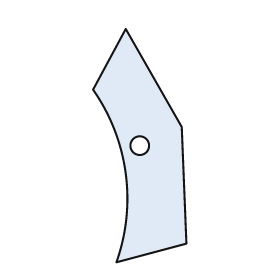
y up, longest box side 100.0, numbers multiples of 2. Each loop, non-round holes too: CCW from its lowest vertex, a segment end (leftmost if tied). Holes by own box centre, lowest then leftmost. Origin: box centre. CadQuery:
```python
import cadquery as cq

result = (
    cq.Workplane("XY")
    .moveTo(-10.0, -50.0)
    .lineTo(20.0, -42.0)
    .lineTo(18.0, 8.0)
    .lineTo(-6.0, 50.0)
    .lineTo(-20.0, 24.0)
    .threePointArc((-6.0, -12.0), (-10.0, -50.0))
    .close()
    .moveTo(0.0, 0.0)
    .circle(4.0)
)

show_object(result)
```